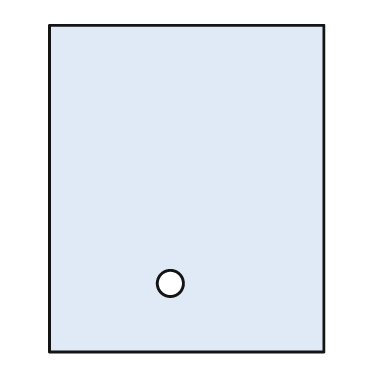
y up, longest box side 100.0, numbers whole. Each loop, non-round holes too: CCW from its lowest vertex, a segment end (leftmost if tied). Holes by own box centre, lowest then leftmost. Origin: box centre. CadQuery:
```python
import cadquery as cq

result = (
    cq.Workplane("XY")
    .moveTo(-42.0, -50.0)
    .lineTo(42.0, -50.0)
    .lineTo(42.0, 50.0)
    .lineTo(-42.0, 50.0)
    .close()
    .moveTo(-5.0, -29.0)
    .circle(4.0)
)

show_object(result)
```